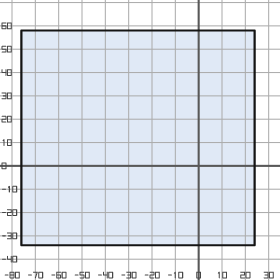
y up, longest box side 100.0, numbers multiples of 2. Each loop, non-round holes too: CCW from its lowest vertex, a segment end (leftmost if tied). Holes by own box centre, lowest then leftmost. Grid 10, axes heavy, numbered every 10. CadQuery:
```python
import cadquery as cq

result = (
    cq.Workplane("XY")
    .moveTo(-76.0, -34.0)
    .lineTo(24.0, -34.0)
    .lineTo(24.0, 58.0)
    .lineTo(-76.0, 58.0)
    .close()
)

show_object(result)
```